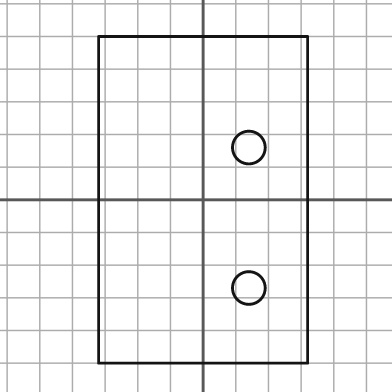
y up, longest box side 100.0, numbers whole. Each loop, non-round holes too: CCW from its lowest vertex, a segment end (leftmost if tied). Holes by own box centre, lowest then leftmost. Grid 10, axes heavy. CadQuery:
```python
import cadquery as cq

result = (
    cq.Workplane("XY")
    .moveTo(-32.0, -50.0)
    .lineTo(32.0, -50.0)
    .lineTo(32.0, 50.0)
    .lineTo(-32.0, 50.0)
    .close()
    .moveTo(14.0, -27.0)
    .circle(5.0)
    .moveTo(14.0, 16.0)
    .circle(5.0)
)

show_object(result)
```